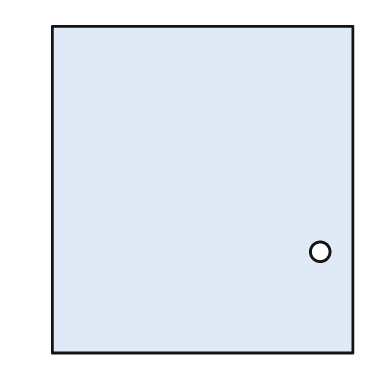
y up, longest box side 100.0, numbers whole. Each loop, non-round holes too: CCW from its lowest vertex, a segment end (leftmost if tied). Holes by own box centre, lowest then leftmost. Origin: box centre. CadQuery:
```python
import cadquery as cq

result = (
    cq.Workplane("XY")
    .moveTo(-46.0, -50.0)
    .lineTo(46.0, -50.0)
    .lineTo(46.0, 50.0)
    .lineTo(-46.0, 50.0)
    .close()
    .moveTo(36.0, -19.0)
    .circle(3.0)
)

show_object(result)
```